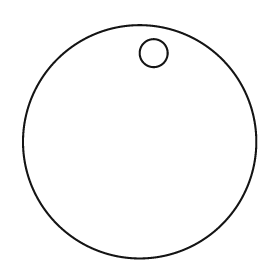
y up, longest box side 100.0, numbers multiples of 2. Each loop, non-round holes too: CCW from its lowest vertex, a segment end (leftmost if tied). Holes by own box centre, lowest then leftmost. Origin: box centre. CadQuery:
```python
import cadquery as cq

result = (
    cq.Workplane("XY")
    .moveTo(0.0, 0.0)
    .circle(50.0)
    .moveTo(6.0, 38.0)
    .circle(6.0)
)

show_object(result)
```